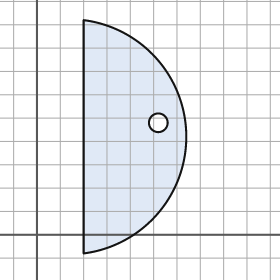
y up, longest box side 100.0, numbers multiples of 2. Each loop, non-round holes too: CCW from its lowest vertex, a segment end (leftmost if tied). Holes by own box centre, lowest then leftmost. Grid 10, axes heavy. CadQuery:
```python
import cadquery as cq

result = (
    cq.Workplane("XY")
    .moveTo(20.0, -8.0)
    .threePointArc((64.0, 42.0), (20.0, 92.0))
    .close()
    .moveTo(52.0, 48.0)
    .circle(4.0)
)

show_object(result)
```